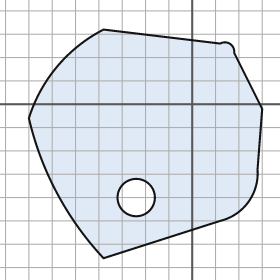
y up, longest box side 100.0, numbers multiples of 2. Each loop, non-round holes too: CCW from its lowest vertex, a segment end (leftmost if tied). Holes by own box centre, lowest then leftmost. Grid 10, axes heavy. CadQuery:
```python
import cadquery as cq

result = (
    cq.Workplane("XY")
    .moveTo(-38.0, -66.0)
    .lineTo(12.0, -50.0)
    .threePointArc((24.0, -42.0), (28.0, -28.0))
    .lineTo(30.0, -2.0)
    .lineTo(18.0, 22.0)
    .threePointArc((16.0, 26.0), (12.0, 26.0))
    .lineTo(-38.0, 32.0)
    .threePointArc((-58.0, 16.0), (-70.0, -6.0))
    .threePointArc((-58.0, -38.0), (-38.0, -66.0))
    .close()
    .moveTo(-24.0, -40.0)
    .circle(8.0)
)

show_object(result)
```